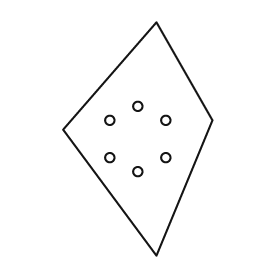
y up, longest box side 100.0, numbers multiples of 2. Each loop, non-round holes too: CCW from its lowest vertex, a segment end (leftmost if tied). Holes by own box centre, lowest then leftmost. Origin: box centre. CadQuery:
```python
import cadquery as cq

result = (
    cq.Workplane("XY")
    .moveTo(8.0, -50.0)
    .lineTo(32.0, 8.0)
    .lineTo(8.0, 50.0)
    .lineTo(-32.0, 4.0)
    .close()
    .moveTo(0.0, -14.0)
    .circle(2.0)
    .moveTo(-12.0, -8.0)
    .circle(2.0)
    .moveTo(12.0, -8.0)
    .circle(2.0)
    .moveTo(-12.0, 8.0)
    .circle(2.0)
    .moveTo(12.0, 8.0)
    .circle(2.0)
    .moveTo(0.0, 14.0)
    .circle(2.0)
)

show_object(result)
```